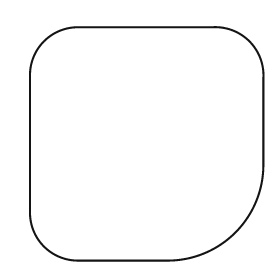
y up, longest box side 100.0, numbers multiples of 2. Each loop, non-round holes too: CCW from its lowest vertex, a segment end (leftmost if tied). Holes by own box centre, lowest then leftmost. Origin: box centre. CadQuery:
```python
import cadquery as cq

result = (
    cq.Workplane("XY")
    .moveTo(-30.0, -50.0)
    .lineTo(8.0, -50.0)
    .threePointArc((38.0, -38.0), (50.0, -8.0))
    .lineTo(50.0, 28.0)
    .threePointArc((44.0, 44.0), (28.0, 50.0))
    .lineTo(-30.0, 50.0)
    .threePointArc((-44.0, 44.0), (-50.0, 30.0))
    .lineTo(-50.0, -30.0)
    .threePointArc((-44.0, -44.0), (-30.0, -50.0))
    .close()
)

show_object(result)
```